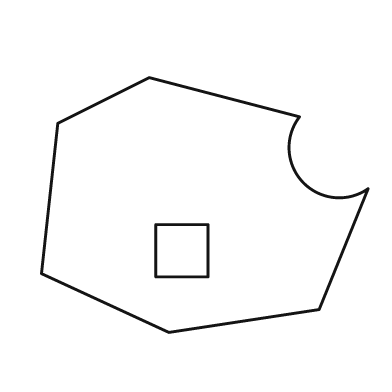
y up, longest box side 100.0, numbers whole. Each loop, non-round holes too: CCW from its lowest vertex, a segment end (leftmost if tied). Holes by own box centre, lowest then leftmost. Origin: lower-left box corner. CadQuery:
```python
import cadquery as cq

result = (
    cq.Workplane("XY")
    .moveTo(39.0, 0.0)
    .lineTo(85.0, 7.0)
    .lineTo(100.0, 44.0)
    .threePointArc((80.0, 46.0), (79.0, 66.0))
    .lineTo(33.0, 78.0)
    .lineTo(5.0, 64.0)
    .lineTo(0.0, 18.0)
    .close()
    .moveTo(35.0, 17.0)
    .lineTo(51.0, 17.0)
    .lineTo(51.0, 33.0)
    .lineTo(35.0, 33.0)
    .close()
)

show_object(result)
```